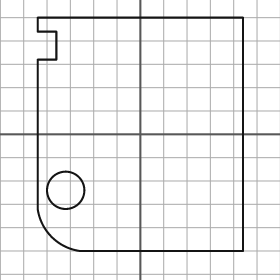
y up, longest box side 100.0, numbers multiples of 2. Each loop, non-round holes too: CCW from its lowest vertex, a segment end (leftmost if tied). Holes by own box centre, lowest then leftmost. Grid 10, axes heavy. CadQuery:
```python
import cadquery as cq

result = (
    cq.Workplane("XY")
    .moveTo(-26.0, -50.0)
    .lineTo(44.0, -50.0)
    .lineTo(44.0, 50.0)
    .lineTo(-44.0, 50.0)
    .lineTo(-44.0, 44.0)
    .lineTo(-36.0, 44.0)
    .lineTo(-36.0, 32.0)
    .lineTo(-44.0, 32.0)
    .lineTo(-44.0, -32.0)
    .threePointArc((-38.0, -44.0), (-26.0, -50.0))
    .close()
    .moveTo(-32.0, -24.0)
    .circle(8.0)
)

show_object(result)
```